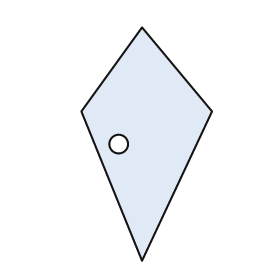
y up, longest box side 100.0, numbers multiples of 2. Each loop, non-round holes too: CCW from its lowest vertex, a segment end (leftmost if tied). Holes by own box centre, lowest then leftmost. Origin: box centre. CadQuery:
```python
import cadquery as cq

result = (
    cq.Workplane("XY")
    .moveTo(-2.0, -50.0)
    .lineTo(28.0, 14.0)
    .lineTo(-2.0, 50.0)
    .lineTo(-28.0, 14.0)
    .close()
    .moveTo(-12.0, 0.0)
    .circle(4.0)
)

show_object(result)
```